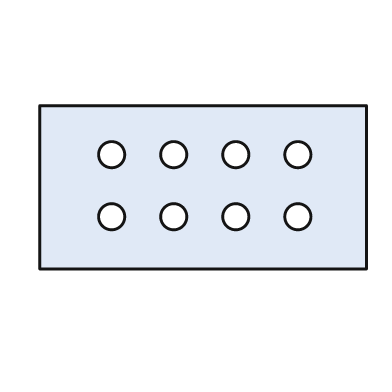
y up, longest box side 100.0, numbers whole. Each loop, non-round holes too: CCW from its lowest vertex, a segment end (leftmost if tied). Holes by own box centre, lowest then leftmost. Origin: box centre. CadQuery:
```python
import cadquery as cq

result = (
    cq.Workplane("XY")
    .moveTo(-50.0, -25.0)
    .lineTo(50.0, -25.0)
    .lineTo(50.0, 25.0)
    .lineTo(-50.0, 25.0)
    .close()
    .moveTo(-28.0, -9.0)
    .circle(4.0)
    .moveTo(-9.0, -9.0)
    .circle(4.0)
    .moveTo(10.0, -9.0)
    .circle(4.0)
    .moveTo(29.0, -9.0)
    .circle(4.0)
    .moveTo(-28.0, 10.0)
    .circle(4.0)
    .moveTo(-9.0, 10.0)
    .circle(4.0)
    .moveTo(10.0, 10.0)
    .circle(4.0)
    .moveTo(29.0, 10.0)
    .circle(4.0)
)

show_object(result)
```